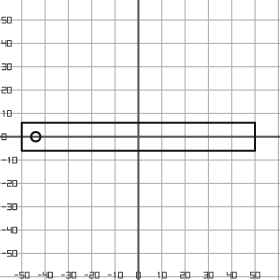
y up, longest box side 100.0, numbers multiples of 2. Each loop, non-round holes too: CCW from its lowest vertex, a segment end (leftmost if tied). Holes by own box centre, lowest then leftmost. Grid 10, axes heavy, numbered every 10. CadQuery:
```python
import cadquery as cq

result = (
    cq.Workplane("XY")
    .moveTo(-50.0, -6.0)
    .lineTo(50.0, -6.0)
    .lineTo(50.0, 6.0)
    .lineTo(-50.0, 6.0)
    .close()
    .moveTo(-44.0, 0.0)
    .circle(2.0)
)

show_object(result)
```